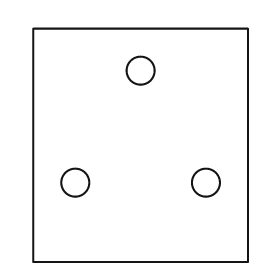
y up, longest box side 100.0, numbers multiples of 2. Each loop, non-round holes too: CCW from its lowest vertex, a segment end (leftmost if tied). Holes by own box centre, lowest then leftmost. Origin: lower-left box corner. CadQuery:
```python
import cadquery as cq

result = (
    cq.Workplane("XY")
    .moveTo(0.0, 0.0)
    .lineTo(92.0, 0.0)
    .lineTo(92.0, 100.0)
    .lineTo(0.0, 100.0)
    .close()
    .moveTo(18.0, 34.0)
    .circle(6.0)
    .moveTo(74.0, 34.0)
    .circle(6.0)
    .moveTo(46.0, 82.0)
    .circle(6.0)
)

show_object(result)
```